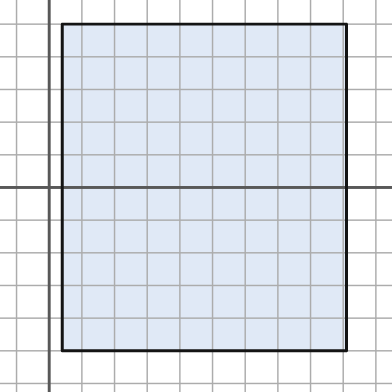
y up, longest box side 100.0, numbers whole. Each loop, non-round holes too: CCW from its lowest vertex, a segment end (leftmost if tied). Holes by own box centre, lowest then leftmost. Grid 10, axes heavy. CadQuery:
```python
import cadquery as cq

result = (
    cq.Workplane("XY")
    .moveTo(4.0, -50.0)
    .lineTo(91.0, -50.0)
    .lineTo(91.0, 50.0)
    .lineTo(4.0, 50.0)
    .close()
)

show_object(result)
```